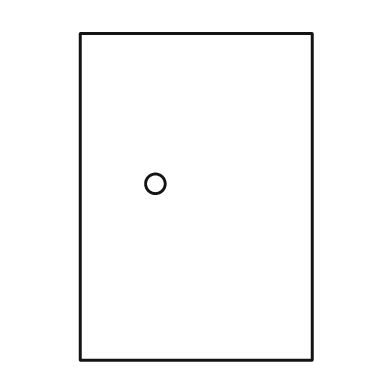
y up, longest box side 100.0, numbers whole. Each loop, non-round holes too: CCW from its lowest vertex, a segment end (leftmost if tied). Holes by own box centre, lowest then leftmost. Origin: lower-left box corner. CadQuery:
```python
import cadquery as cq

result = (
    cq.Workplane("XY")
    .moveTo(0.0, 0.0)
    .lineTo(71.0, 0.0)
    .lineTo(71.0, 100.0)
    .lineTo(0.0, 100.0)
    .close()
    .moveTo(23.0, 54.0)
    .circle(3.0)
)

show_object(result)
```